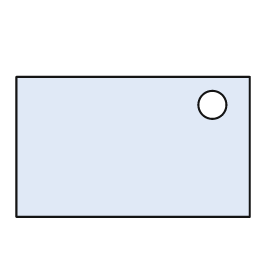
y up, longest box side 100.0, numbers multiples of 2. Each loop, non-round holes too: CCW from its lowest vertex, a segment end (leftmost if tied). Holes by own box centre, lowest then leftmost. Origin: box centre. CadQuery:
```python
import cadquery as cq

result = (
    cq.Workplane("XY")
    .moveTo(-50.0, -30.0)
    .lineTo(50.0, -30.0)
    .lineTo(50.0, 30.0)
    .lineTo(-50.0, 30.0)
    .close()
    .moveTo(34.0, 18.0)
    .circle(6.0)
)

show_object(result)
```